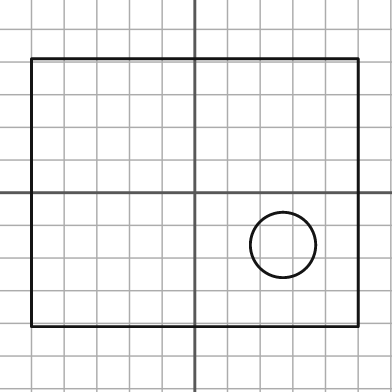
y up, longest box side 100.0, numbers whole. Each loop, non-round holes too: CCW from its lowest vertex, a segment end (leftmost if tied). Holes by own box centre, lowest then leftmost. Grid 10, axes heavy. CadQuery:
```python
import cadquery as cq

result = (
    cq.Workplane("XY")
    .moveTo(-50.0, -41.0)
    .lineTo(50.0, -41.0)
    .lineTo(50.0, 41.0)
    .lineTo(-50.0, 41.0)
    .close()
    .moveTo(27.0, -16.0)
    .circle(10.0)
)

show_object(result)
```